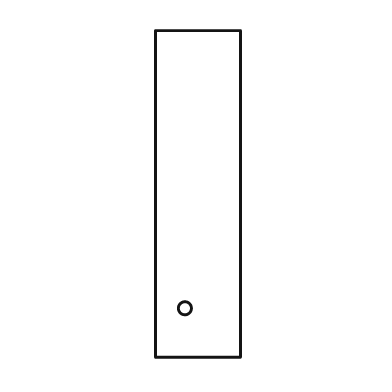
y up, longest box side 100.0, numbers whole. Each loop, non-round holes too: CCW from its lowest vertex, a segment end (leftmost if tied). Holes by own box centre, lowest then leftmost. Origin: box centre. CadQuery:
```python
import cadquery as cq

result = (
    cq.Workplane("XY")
    .moveTo(-13.0, -50.0)
    .lineTo(13.0, -50.0)
    .lineTo(13.0, 50.0)
    .lineTo(-13.0, 50.0)
    .close()
    .moveTo(-4.0, -35.0)
    .circle(2.0)
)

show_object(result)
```